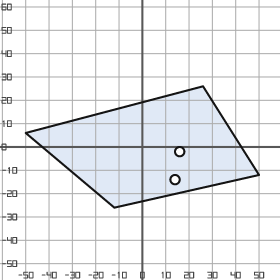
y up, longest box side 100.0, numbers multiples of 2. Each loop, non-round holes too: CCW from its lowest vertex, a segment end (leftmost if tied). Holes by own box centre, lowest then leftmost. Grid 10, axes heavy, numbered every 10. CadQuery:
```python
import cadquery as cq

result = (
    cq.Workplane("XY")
    .moveTo(-12.0, -26.0)
    .lineTo(50.0, -12.0)
    .lineTo(26.0, 26.0)
    .lineTo(-50.0, 6.0)
    .close()
    .moveTo(14.0, -14.0)
    .circle(2.0)
    .moveTo(16.0, -2.0)
    .circle(2.0)
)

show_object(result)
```